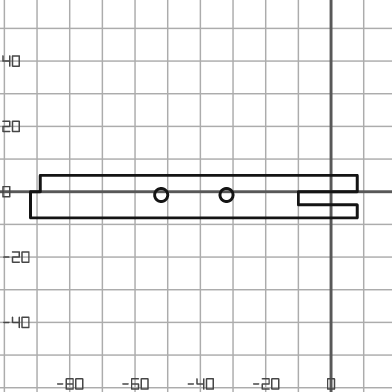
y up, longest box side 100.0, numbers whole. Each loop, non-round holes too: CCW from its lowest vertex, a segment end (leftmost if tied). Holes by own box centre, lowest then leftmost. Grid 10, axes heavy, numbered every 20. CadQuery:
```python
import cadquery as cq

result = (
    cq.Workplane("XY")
    .moveTo(-92.0, -8.0)
    .lineTo(8.0, -8.0)
    .lineTo(8.0, -4.0)
    .lineTo(-10.0, -4.0)
    .lineTo(-10.0, 0.0)
    .lineTo(8.0, 0.0)
    .lineTo(8.0, 5.0)
    .lineTo(-89.0, 5.0)
    .lineTo(-89.0, 0.0)
    .lineTo(-92.0, 0.0)
    .close()
    .moveTo(-52.0, -1.0)
    .circle(2.0)
    .moveTo(-32.0, -1.0)
    .circle(2.0)
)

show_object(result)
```